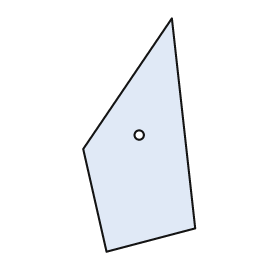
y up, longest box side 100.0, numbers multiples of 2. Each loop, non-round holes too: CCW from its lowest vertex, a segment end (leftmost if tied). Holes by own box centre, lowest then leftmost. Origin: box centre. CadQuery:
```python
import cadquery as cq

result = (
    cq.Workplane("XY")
    .moveTo(-14.0, -50.0)
    .lineTo(24.0, -40.0)
    .lineTo(14.0, 50.0)
    .lineTo(-24.0, -6.0)
    .close()
    .moveTo(0.0, 0.0)
    .circle(2.0)
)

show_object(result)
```